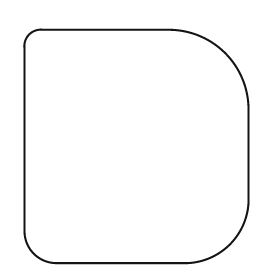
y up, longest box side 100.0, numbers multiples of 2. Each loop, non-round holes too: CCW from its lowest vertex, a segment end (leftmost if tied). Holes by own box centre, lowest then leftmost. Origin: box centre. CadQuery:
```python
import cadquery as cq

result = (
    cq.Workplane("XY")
    .moveTo(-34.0, -50.0)
    .lineTo(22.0, -50.0)
    .threePointArc((40.0, -42.0), (48.0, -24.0))
    .lineTo(48.0, 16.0)
    .threePointArc((38.0, 40.0), (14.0, 50.0))
    .lineTo(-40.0, 50.0)
    .threePointArc((-46.0, 48.0), (-48.0, 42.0))
    .lineTo(-48.0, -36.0)
    .threePointArc((-44.0, -46.0), (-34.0, -50.0))
    .close()
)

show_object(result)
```